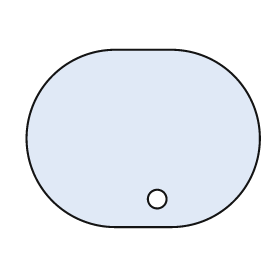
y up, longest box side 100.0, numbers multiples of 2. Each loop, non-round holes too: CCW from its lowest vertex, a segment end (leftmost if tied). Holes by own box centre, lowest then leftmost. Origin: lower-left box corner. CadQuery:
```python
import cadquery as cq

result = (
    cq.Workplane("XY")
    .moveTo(38.0, 0.0)
    .lineTo(62.0, 0.0)
    .threePointArc((100.0, 38.0), (62.0, 76.0))
    .lineTo(38.0, 76.0)
    .threePointArc((0.0, 38.0), (38.0, 0.0))
    .close()
    .moveTo(56.0, 12.0)
    .circle(4.0)
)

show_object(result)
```